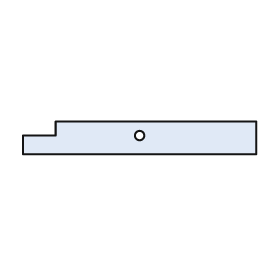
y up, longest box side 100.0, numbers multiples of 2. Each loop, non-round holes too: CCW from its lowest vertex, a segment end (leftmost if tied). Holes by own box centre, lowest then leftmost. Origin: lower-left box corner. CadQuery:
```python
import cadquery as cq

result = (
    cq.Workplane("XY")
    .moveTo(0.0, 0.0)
    .lineTo(100.0, 0.0)
    .lineTo(100.0, 14.0)
    .lineTo(14.0, 14.0)
    .lineTo(14.0, 8.0)
    .lineTo(0.0, 8.0)
    .close()
    .moveTo(50.0, 8.0)
    .circle(2.0)
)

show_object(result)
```